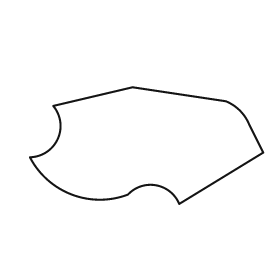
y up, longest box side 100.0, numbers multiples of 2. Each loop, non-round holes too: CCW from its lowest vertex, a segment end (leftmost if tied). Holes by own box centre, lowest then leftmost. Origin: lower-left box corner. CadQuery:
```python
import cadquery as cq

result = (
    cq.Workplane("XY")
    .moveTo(64.0, 0.0)
    .lineTo(100.0, 22.0)
    .lineTo(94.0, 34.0)
    .threePointArc((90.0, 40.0), (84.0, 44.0))
    .lineTo(44.0, 50.0)
    .lineTo(10.0, 42.0)
    .threePointArc((12.0, 28.0), (0.0, 20.0))
    .threePointArc((18.0, 4.0), (42.0, 4.0))
    .threePointArc((54.0, 8.0), (64.0, 0.0))
    .close()
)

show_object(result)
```